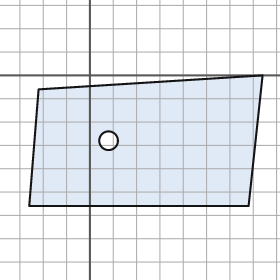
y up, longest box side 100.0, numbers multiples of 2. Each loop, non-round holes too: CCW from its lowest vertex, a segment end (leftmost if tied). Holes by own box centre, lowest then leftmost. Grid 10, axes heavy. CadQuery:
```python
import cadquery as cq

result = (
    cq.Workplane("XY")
    .moveTo(-26.0, -56.0)
    .lineTo(68.0, -56.0)
    .lineTo(74.0, 0.0)
    .lineTo(-22.0, -6.0)
    .close()
    .moveTo(8.0, -28.0)
    .circle(4.0)
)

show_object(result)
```